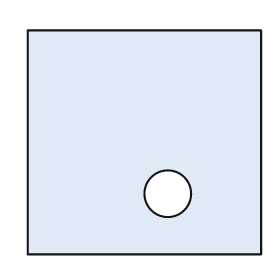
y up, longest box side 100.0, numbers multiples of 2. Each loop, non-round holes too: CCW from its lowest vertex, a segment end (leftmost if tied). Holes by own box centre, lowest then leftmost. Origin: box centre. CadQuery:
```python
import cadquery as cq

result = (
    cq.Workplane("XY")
    .moveTo(-50.0, -48.0)
    .lineTo(50.0, -48.0)
    .lineTo(50.0, 48.0)
    .lineTo(-50.0, 48.0)
    .close()
    .moveTo(10.0, -22.0)
    .circle(10.0)
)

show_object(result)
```